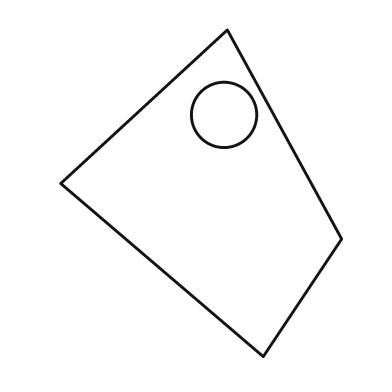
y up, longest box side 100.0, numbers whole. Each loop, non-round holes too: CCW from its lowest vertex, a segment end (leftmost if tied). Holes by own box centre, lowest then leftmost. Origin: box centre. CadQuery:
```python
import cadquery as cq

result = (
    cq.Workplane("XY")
    .moveTo(19.0, -50.0)
    .lineTo(43.0, -14.0)
    .lineTo(8.0, 50.0)
    .lineTo(-43.0, 3.0)
    .close()
    .moveTo(7.0, 24.0)
    .circle(10.0)
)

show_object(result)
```